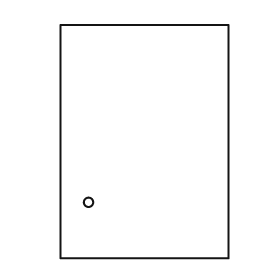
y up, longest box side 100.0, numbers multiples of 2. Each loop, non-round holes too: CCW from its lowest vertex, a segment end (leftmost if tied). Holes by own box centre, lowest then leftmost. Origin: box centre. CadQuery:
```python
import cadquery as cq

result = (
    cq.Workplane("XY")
    .moveTo(-36.0, -50.0)
    .lineTo(36.0, -50.0)
    .lineTo(36.0, 50.0)
    .lineTo(-36.0, 50.0)
    .close()
    .moveTo(-24.0, -26.0)
    .circle(2.0)
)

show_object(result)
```